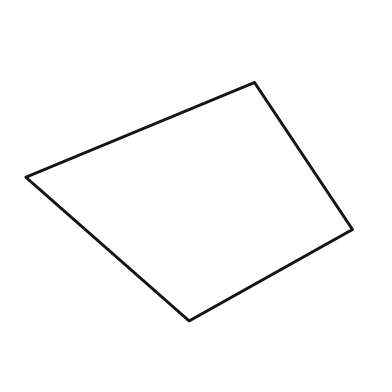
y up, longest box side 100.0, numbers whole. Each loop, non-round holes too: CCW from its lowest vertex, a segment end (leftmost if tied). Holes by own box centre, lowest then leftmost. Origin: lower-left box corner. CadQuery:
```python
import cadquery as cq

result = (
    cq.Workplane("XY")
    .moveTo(50.0, 0.0)
    .lineTo(100.0, 28.0)
    .lineTo(70.0, 73.0)
    .lineTo(0.0, 44.0)
    .close()
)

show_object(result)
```